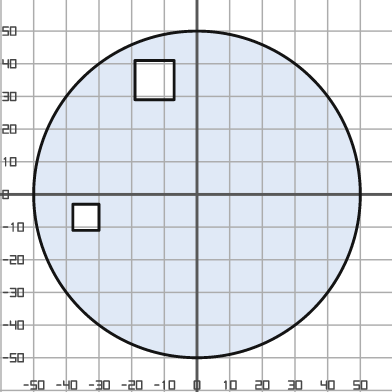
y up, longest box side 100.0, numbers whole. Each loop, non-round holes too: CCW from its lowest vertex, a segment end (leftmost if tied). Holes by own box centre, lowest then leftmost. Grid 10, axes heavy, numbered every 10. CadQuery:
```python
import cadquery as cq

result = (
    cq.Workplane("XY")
    .moveTo(0.0, 0.0)
    .circle(50.0)
    .moveTo(-38.0, -11.0)
    .lineTo(-30.0, -11.0)
    .lineTo(-30.0, -3.0)
    .lineTo(-38.0, -3.0)
    .close()
    .moveTo(-19.0, 29.0)
    .lineTo(-7.0, 29.0)
    .lineTo(-7.0, 41.0)
    .lineTo(-19.0, 41.0)
    .close()
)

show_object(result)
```